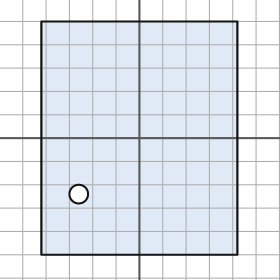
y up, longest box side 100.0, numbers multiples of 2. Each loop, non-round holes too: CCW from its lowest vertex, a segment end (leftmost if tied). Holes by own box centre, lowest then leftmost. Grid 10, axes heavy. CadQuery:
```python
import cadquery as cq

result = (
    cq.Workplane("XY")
    .moveTo(-42.0, -50.0)
    .lineTo(42.0, -50.0)
    .lineTo(42.0, 50.0)
    .lineTo(-42.0, 50.0)
    .close()
    .moveTo(-26.0, -24.0)
    .circle(4.0)
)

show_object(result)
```